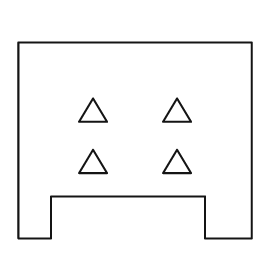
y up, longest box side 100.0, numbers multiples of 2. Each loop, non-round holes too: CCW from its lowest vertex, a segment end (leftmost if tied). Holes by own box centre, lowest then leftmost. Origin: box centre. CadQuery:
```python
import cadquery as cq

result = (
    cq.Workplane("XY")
    .moveTo(-50.0, -42.0)
    .lineTo(-36.0, -42.0)
    .lineTo(-36.0, -24.0)
    .lineTo(30.0, -24.0)
    .lineTo(30.0, -42.0)
    .lineTo(50.0, -42.0)
    .lineTo(50.0, 42.0)
    .lineTo(-50.0, 42.0)
    .close()
    .moveTo(-24.0, -14.0)
    .lineTo(-12.0, -14.0)
    .lineTo(-18.0, -4.0)
    .close()
    .moveTo(12.0, -14.0)
    .lineTo(24.0, -14.0)
    .lineTo(18.0, -4.0)
    .close()
    .moveTo(-24.0, 8.0)
    .lineTo(-12.0, 8.0)
    .lineTo(-18.0, 18.0)
    .close()
    .moveTo(12.0, 8.0)
    .lineTo(24.0, 8.0)
    .lineTo(18.0, 18.0)
    .close()
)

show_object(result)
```